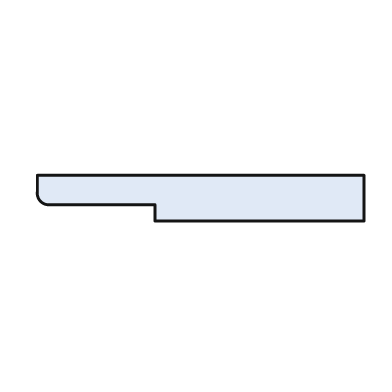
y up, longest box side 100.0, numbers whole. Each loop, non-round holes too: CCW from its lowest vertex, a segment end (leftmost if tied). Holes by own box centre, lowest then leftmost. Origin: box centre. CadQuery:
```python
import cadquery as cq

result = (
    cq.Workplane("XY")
    .moveTo(-14.0, -7.0)
    .lineTo(50.0, -7.0)
    .lineTo(50.0, 7.0)
    .lineTo(-50.0, 7.0)
    .lineTo(-50.0, 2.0)
    .threePointArc((-49.0, -1.0), (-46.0, -2.0))
    .lineTo(-14.0, -2.0)
    .close()
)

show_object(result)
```